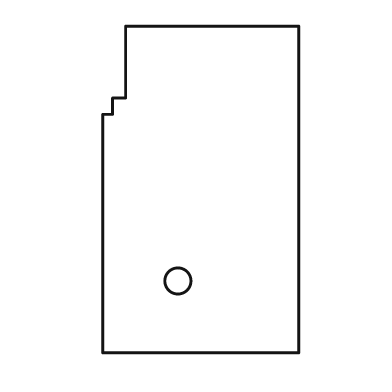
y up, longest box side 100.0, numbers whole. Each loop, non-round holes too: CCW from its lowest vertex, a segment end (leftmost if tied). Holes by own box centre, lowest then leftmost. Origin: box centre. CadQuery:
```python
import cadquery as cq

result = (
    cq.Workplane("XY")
    .moveTo(-30.0, -50.0)
    .lineTo(30.0, -50.0)
    .lineTo(30.0, 50.0)
    .lineTo(-23.0, 50.0)
    .lineTo(-23.0, 28.0)
    .lineTo(-27.0, 28.0)
    .lineTo(-27.0, 23.0)
    .lineTo(-30.0, 23.0)
    .close()
    .moveTo(-7.0, -28.0)
    .circle(4.0)
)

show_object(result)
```